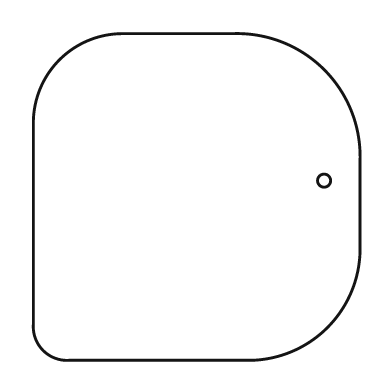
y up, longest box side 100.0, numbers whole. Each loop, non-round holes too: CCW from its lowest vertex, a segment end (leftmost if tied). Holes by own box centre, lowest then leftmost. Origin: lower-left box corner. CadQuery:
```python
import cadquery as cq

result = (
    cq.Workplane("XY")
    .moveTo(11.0, 0.0)
    .lineTo(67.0, 0.0)
    .threePointArc((90.0, 10.0), (100.0, 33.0))
    .lineTo(100.0, 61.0)
    .threePointArc((89.0, 89.0), (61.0, 100.0))
    .lineTo(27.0, 100.0)
    .threePointArc((8.0, 92.0), (0.0, 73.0))
    .lineTo(0.0, 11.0)
    .threePointArc((3.0, 3.0), (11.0, 0.0))
    .close()
    .moveTo(89.0, 55.0)
    .circle(2.0)
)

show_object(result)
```